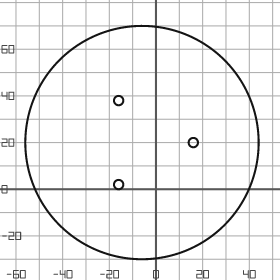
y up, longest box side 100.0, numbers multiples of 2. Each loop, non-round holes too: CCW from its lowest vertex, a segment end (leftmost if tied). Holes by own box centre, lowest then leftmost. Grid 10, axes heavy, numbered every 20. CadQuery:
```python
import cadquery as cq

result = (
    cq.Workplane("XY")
    .moveTo(-6.0, 20.0)
    .circle(50.0)
    .moveTo(-16.0, 2.0)
    .circle(2.0)
    .moveTo(16.0, 20.0)
    .circle(2.0)
    .moveTo(-16.0, 38.0)
    .circle(2.0)
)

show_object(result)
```